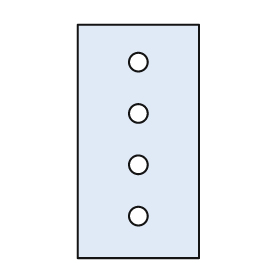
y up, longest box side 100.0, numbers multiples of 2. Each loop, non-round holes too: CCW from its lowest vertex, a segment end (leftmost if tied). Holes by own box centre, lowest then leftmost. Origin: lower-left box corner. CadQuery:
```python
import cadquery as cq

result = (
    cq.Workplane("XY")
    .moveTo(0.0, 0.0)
    .lineTo(52.0, 0.0)
    .lineTo(52.0, 100.0)
    .lineTo(0.0, 100.0)
    .close()
    .moveTo(26.0, 18.0)
    .circle(4.0)
    .moveTo(26.0, 40.0)
    .circle(4.0)
    .moveTo(26.0, 62.0)
    .circle(4.0)
    .moveTo(26.0, 84.0)
    .circle(4.0)
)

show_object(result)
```